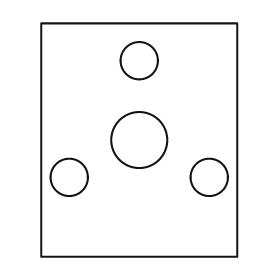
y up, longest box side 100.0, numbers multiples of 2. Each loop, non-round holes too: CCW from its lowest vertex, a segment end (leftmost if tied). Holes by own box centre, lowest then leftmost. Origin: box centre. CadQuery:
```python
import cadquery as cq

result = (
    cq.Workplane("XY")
    .moveTo(-42.0, -50.0)
    .lineTo(42.0, -50.0)
    .lineTo(42.0, 50.0)
    .lineTo(-42.0, 50.0)
    .close()
    .moveTo(-30.0, -16.0)
    .circle(8.0)
    .moveTo(30.0, -16.0)
    .circle(8.0)
    .moveTo(0.0, 0.0)
    .circle(12.0)
    .moveTo(0.0, 34.0)
    .circle(8.0)
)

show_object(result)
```